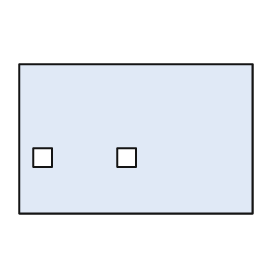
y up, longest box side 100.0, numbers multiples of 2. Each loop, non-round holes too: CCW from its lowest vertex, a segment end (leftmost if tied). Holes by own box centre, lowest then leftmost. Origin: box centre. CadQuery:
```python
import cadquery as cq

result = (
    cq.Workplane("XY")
    .moveTo(-50.0, -32.0)
    .lineTo(50.0, -32.0)
    .lineTo(50.0, 32.0)
    .lineTo(-50.0, 32.0)
    .close()
    .moveTo(-44.0, -12.0)
    .lineTo(-36.0, -12.0)
    .lineTo(-36.0, -4.0)
    .lineTo(-44.0, -4.0)
    .close()
    .moveTo(-8.0, -12.0)
    .lineTo(0.0, -12.0)
    .lineTo(0.0, -4.0)
    .lineTo(-8.0, -4.0)
    .close()
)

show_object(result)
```